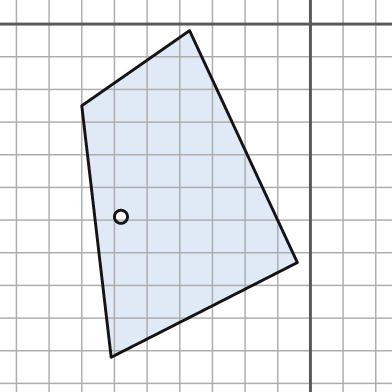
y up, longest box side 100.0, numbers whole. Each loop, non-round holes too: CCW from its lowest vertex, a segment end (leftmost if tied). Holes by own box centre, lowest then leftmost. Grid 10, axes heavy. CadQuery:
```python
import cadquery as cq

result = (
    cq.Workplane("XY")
    .moveTo(-61.0, -102.0)
    .lineTo(-4.0, -73.0)
    .lineTo(-37.0, -2.0)
    .lineTo(-70.0, -25.0)
    .close()
    .moveTo(-58.0, -59.0)
    .circle(2.0)
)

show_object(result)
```